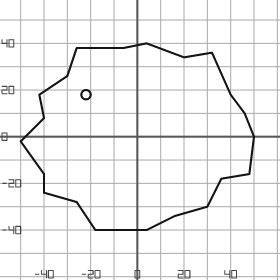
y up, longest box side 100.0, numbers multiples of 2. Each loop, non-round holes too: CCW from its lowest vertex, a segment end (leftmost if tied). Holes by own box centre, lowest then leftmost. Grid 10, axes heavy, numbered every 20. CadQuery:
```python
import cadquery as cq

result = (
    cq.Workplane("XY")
    .moveTo(-18.0, -40.0)
    .lineTo(4.0, -40.0)
    .lineTo(16.0, -34.0)
    .lineTo(30.0, -30.0)
    .lineTo(36.0, -18.0)
    .lineTo(48.0, -16.0)
    .lineTo(50.0, 0.0)
    .lineTo(46.0, 10.0)
    .lineTo(40.0, 18.0)
    .lineTo(32.0, 36.0)
    .lineTo(20.0, 34.0)
    .lineTo(4.0, 40.0)
    .lineTo(-6.0, 38.0)
    .lineTo(-26.0, 38.0)
    .lineTo(-30.0, 26.0)
    .lineTo(-42.0, 18.0)
    .lineTo(-40.0, 8.0)
    .lineTo(-50.0, -2.0)
    .lineTo(-40.0, -16.0)
    .lineTo(-40.0, -24.0)
    .lineTo(-26.0, -28.0)
    .close()
    .moveTo(-22.0, 18.0)
    .circle(2.0)
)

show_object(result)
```